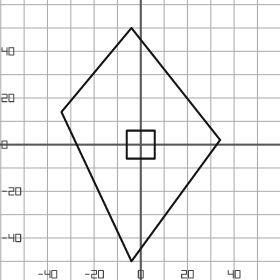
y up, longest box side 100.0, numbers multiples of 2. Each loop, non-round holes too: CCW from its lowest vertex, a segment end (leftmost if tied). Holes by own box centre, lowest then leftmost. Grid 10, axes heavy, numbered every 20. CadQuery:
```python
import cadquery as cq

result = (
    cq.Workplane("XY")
    .moveTo(-4.0, -50.0)
    .lineTo(34.0, 2.0)
    .lineTo(-4.0, 50.0)
    .lineTo(-34.0, 14.0)
    .close()
    .moveTo(-6.0, -6.0)
    .lineTo(6.0, -6.0)
    .lineTo(6.0, 6.0)
    .lineTo(-6.0, 6.0)
    .close()
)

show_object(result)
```